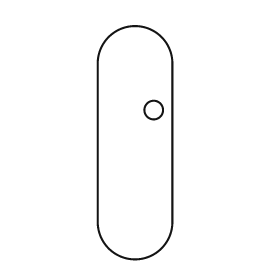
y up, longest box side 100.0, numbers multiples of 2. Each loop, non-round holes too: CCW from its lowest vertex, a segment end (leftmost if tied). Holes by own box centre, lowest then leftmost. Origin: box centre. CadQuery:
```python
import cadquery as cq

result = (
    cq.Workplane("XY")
    .moveTo(-16.0, -34.0)
    .threePointArc((0.0, -50.0), (16.0, -34.0))
    .lineTo(16.0, 34.0)
    .threePointArc((0.0, 50.0), (-16.0, 34.0))
    .close()
    .moveTo(8.0, 14.0)
    .circle(4.0)
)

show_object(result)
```